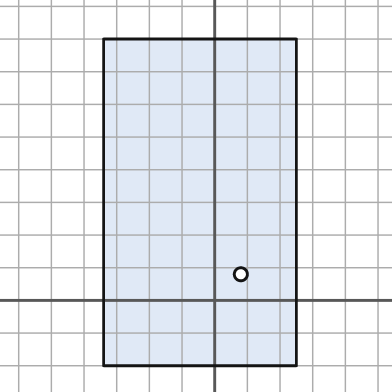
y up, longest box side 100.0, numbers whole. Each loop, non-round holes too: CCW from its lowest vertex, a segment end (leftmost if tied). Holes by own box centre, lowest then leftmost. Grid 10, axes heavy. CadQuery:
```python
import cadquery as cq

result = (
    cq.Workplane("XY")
    .moveTo(-34.0, -20.0)
    .lineTo(25.0, -20.0)
    .lineTo(25.0, 80.0)
    .lineTo(-34.0, 80.0)
    .close()
    .moveTo(8.0, 8.0)
    .circle(2.0)
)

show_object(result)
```